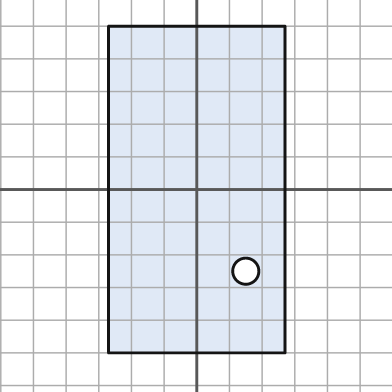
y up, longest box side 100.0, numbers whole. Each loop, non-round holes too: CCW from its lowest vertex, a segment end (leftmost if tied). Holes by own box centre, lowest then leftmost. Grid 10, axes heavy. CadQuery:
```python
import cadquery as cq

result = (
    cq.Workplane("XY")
    .moveTo(-27.0, -50.0)
    .lineTo(27.0, -50.0)
    .lineTo(27.0, 50.0)
    .lineTo(-27.0, 50.0)
    .close()
    .moveTo(15.0, -25.0)
    .circle(4.0)
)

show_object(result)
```